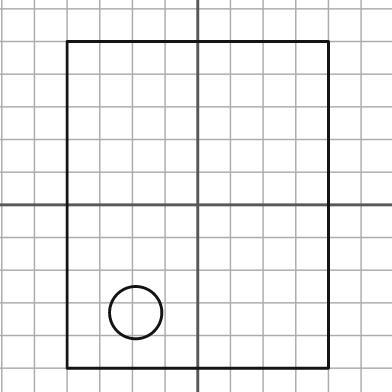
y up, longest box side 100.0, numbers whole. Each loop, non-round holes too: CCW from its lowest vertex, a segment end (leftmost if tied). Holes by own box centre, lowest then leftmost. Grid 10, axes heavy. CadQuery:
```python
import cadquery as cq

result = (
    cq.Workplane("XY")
    .moveTo(-40.0, -50.0)
    .lineTo(40.0, -50.0)
    .lineTo(40.0, 50.0)
    .lineTo(-40.0, 50.0)
    .close()
    .moveTo(-19.0, -33.0)
    .circle(8.0)
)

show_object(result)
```